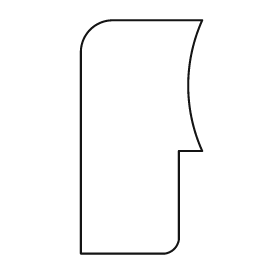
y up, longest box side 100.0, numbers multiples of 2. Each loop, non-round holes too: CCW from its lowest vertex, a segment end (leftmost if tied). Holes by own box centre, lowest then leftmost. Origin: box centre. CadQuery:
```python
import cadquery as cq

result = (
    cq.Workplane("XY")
    .moveTo(-26.0, -50.0)
    .lineTo(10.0, -50.0)
    .threePointArc((14.0, -48.0), (16.0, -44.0))
    .lineTo(16.0, -6.0)
    .lineTo(26.0, -6.0)
    .threePointArc((20.0, 22.0), (26.0, 50.0))
    .lineTo(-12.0, 50.0)
    .threePointArc((-22.0, 46.0), (-26.0, 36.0))
    .close()
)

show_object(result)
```